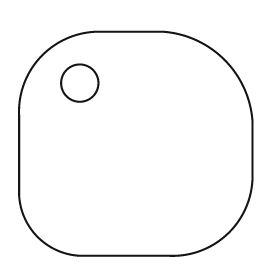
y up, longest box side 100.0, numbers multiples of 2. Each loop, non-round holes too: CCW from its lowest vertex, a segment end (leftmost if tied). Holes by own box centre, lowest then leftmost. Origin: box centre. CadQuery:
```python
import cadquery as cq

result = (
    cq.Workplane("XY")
    .moveTo(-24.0, -48.0)
    .lineTo(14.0, -48.0)
    .threePointArc((40.0, -38.0), (50.0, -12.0))
    .lineTo(50.0, 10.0)
    .threePointArc((38.0, 36.0), (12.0, 48.0))
    .lineTo(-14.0, 48.0)
    .threePointArc((-40.0, 38.0), (-50.0, 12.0))
    .lineTo(-50.0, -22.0)
    .threePointArc((-42.0, -40.0), (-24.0, -48.0))
    .close()
    .moveTo(-24.0, 26.0)
    .circle(8.0)
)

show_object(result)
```